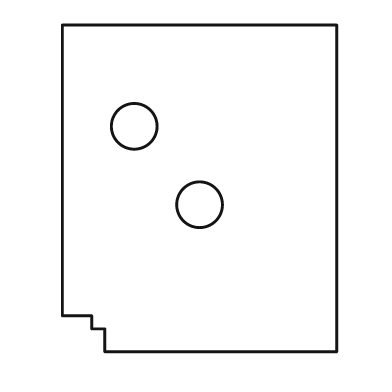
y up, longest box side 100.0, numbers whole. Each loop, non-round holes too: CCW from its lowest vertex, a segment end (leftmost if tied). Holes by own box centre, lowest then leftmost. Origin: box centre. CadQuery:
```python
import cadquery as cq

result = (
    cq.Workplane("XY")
    .moveTo(-29.0, -50.0)
    .lineTo(42.0, -50.0)
    .lineTo(42.0, 50.0)
    .lineTo(-42.0, 50.0)
    .lineTo(-42.0, -39.0)
    .lineTo(-33.0, -39.0)
    .lineTo(-33.0, -43.0)
    .lineTo(-29.0, -43.0)
    .close()
    .moveTo(0.0, -5.0)
    .circle(7.0)
    .moveTo(-20.0, 19.0)
    .circle(7.0)
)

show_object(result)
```